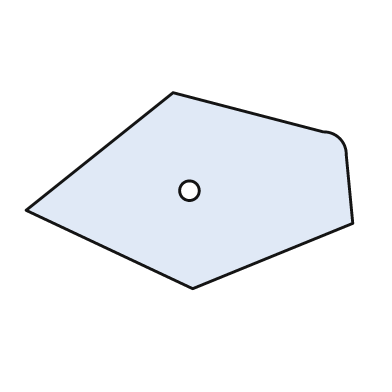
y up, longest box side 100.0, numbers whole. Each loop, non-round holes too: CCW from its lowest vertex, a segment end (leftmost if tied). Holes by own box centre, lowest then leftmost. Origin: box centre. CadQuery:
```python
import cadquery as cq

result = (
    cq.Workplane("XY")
    .moveTo(1.0, -30.0)
    .lineTo(50.0, -10.0)
    .lineTo(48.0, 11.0)
    .threePointArc((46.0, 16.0), (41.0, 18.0))
    .lineTo(-5.0, 30.0)
    .lineTo(-50.0, -6.0)
    .close()
    .moveTo(0.0, 0.0)
    .circle(3.0)
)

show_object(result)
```